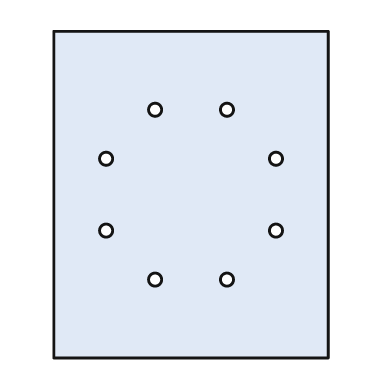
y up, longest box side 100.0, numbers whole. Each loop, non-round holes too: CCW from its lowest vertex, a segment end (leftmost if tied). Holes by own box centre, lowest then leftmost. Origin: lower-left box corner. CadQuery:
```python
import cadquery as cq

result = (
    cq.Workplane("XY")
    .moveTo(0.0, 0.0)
    .lineTo(84.0, 0.0)
    .lineTo(84.0, 100.0)
    .lineTo(0.0, 100.0)
    .close()
    .moveTo(31.0, 24.0)
    .circle(2.0)
    .moveTo(53.0, 24.0)
    .circle(2.0)
    .moveTo(16.0, 39.0)
    .circle(2.0)
    .moveTo(68.0, 39.0)
    .circle(2.0)
    .moveTo(16.0, 61.0)
    .circle(2.0)
    .moveTo(68.0, 61.0)
    .circle(2.0)
    .moveTo(31.0, 76.0)
    .circle(2.0)
    .moveTo(53.0, 76.0)
    .circle(2.0)
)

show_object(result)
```